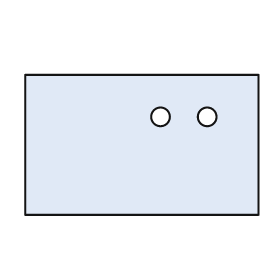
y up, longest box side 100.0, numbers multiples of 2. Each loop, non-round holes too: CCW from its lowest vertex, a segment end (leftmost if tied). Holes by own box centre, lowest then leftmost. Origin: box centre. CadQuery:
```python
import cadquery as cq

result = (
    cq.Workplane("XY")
    .moveTo(-50.0, -30.0)
    .lineTo(50.0, -30.0)
    .lineTo(50.0, 30.0)
    .lineTo(-50.0, 30.0)
    .close()
    .moveTo(8.0, 12.0)
    .circle(4.0)
    .moveTo(28.0, 12.0)
    .circle(4.0)
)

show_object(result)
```